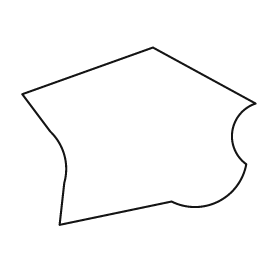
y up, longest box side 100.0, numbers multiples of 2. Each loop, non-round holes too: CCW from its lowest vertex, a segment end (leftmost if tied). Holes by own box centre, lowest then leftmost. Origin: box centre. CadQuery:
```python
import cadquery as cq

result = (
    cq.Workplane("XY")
    .moveTo(-34.0, -38.0)
    .lineTo(14.0, -28.0)
    .threePointArc((34.0, -28.0), (46.0, -12.0))
    .threePointArc((40.0, 2.0), (50.0, 14.0))
    .lineTo(6.0, 38.0)
    .lineTo(-50.0, 18.0)
    .lineTo(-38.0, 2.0)
    .threePointArc((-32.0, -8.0), (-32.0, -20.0))
    .close()
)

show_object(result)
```